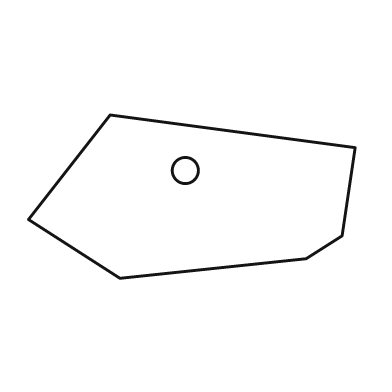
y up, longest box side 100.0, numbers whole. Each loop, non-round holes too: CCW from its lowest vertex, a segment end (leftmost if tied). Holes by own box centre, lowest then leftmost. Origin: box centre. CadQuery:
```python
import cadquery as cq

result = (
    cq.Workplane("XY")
    .moveTo(-22.0, -25.0)
    .lineTo(35.0, -19.0)
    .lineTo(46.0, -12.0)
    .lineTo(50.0, 15.0)
    .lineTo(-25.0, 25.0)
    .lineTo(-50.0, -7.0)
    .close()
    .moveTo(-2.0, 8.0)
    .circle(4.0)
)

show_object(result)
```